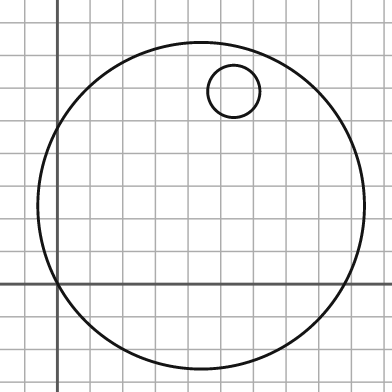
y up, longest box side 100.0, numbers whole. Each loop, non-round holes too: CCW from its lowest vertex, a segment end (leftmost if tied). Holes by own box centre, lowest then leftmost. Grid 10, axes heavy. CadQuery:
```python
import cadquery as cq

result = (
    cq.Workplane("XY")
    .moveTo(44.0, 24.0)
    .circle(50.0)
    .moveTo(54.0, 59.0)
    .circle(8.0)
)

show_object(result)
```